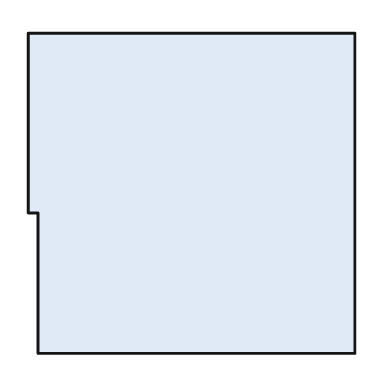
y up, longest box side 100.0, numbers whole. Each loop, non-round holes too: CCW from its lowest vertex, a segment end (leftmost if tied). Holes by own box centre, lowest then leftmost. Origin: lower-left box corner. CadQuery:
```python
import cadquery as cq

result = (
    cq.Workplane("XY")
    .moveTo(3.0, 0.0)
    .lineTo(100.0, 0.0)
    .lineTo(100.0, 98.0)
    .lineTo(0.0, 98.0)
    .lineTo(0.0, 43.0)
    .lineTo(3.0, 43.0)
    .close()
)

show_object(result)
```